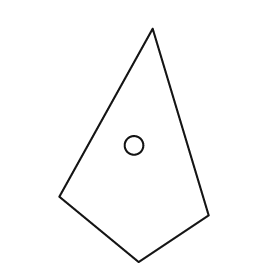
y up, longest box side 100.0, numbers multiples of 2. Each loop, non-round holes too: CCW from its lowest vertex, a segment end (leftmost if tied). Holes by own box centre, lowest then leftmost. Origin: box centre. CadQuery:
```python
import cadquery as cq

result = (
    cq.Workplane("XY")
    .moveTo(2.0, -50.0)
    .lineTo(32.0, -30.0)
    .lineTo(8.0, 50.0)
    .lineTo(-32.0, -22.0)
    .close()
    .moveTo(0.0, 0.0)
    .circle(4.0)
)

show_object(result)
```